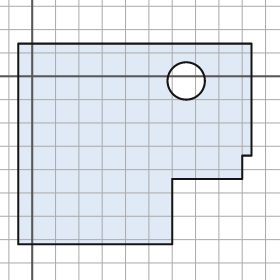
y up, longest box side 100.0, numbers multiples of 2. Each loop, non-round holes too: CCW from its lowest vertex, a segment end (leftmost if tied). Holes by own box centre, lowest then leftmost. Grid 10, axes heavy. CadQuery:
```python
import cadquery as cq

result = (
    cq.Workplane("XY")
    .moveTo(-6.0, -72.0)
    .lineTo(60.0, -72.0)
    .lineTo(60.0, -44.0)
    .lineTo(90.0, -44.0)
    .lineTo(90.0, -34.0)
    .lineTo(94.0, -34.0)
    .lineTo(94.0, 14.0)
    .lineTo(-6.0, 14.0)
    .close()
    .moveTo(66.0, -2.0)
    .circle(8.0)
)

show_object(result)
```